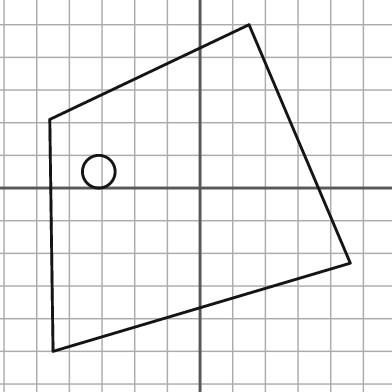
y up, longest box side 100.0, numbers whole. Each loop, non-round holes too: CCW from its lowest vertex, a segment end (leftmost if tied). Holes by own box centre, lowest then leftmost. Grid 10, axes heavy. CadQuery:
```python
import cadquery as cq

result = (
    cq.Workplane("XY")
    .moveTo(-45.0, -50.0)
    .lineTo(46.0, -23.0)
    .lineTo(15.0, 50.0)
    .lineTo(-46.0, 21.0)
    .close()
    .moveTo(-31.0, 5.0)
    .circle(5.0)
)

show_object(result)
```